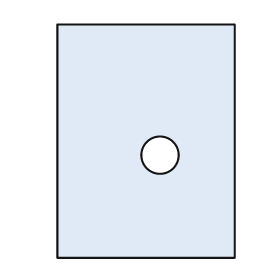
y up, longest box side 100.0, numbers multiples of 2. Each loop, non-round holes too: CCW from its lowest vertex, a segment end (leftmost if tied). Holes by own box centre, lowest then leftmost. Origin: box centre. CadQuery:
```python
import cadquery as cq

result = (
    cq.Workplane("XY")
    .moveTo(-38.0, -50.0)
    .lineTo(38.0, -50.0)
    .lineTo(38.0, 50.0)
    .lineTo(-38.0, 50.0)
    .close()
    .moveTo(6.0, -6.0)
    .circle(8.0)
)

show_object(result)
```